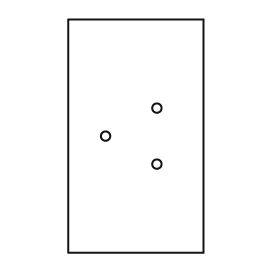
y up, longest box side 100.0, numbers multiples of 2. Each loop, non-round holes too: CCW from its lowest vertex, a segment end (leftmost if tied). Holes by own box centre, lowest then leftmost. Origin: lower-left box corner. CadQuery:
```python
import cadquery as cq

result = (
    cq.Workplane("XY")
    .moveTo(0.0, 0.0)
    .lineTo(58.0, 0.0)
    .lineTo(58.0, 100.0)
    .lineTo(0.0, 100.0)
    .close()
    .moveTo(38.0, 38.0)
    .circle(2.0)
    .moveTo(16.0, 50.0)
    .circle(2.0)
    .moveTo(38.0, 62.0)
    .circle(2.0)
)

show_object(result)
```